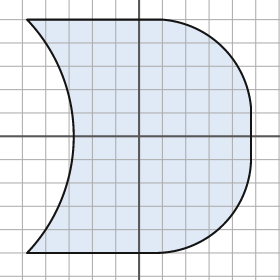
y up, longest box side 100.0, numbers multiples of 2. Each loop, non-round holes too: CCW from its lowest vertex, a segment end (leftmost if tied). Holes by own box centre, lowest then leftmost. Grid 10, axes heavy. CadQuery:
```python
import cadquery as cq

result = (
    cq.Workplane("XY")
    .moveTo(-48.0, -50.0)
    .lineTo(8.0, -50.0)
    .threePointArc((36.0, -38.0), (48.0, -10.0))
    .lineTo(48.0, 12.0)
    .threePointArc((36.0, 38.0), (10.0, 50.0))
    .lineTo(-48.0, 50.0)
    .threePointArc((-28.0, 0.0), (-48.0, -50.0))
    .close()
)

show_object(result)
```